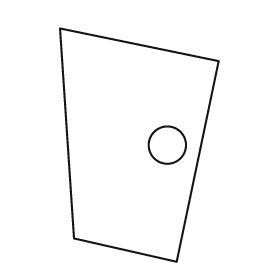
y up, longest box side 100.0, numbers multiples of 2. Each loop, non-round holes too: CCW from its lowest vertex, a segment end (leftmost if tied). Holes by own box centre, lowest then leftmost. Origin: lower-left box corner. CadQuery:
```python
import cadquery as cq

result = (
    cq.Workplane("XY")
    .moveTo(50.0, 0.0)
    .lineTo(68.0, 86.0)
    .lineTo(0.0, 100.0)
    .lineTo(6.0, 10.0)
    .close()
    .moveTo(46.0, 50.0)
    .circle(8.0)
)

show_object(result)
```